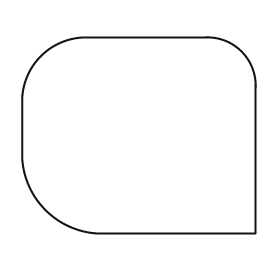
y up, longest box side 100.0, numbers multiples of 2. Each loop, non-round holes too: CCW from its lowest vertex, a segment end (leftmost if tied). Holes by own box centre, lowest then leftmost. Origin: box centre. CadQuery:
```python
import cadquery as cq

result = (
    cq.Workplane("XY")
    .moveTo(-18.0, -42.0)
    .lineTo(50.0, -42.0)
    .lineTo(50.0, 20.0)
    .threePointArc((44.0, 36.0), (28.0, 42.0))
    .lineTo(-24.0, 42.0)
    .threePointArc((-42.0, 34.0), (-50.0, 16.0))
    .lineTo(-50.0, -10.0)
    .threePointArc((-40.0, -32.0), (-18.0, -42.0))
    .close()
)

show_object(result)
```